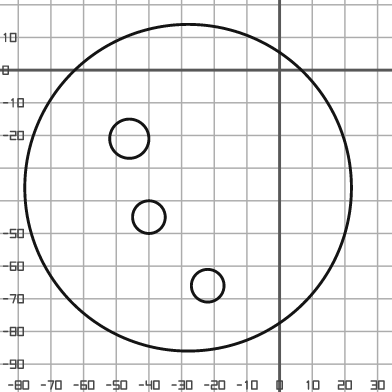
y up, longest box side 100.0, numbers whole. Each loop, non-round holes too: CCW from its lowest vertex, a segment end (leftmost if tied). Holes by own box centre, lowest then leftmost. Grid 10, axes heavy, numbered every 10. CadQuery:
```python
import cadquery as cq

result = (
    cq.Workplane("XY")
    .moveTo(-28.0, -36.0)
    .circle(50.0)
    .moveTo(-22.0, -66.0)
    .circle(5.0)
    .moveTo(-40.0, -45.0)
    .circle(5.0)
    .moveTo(-46.0, -21.0)
    .circle(6.0)
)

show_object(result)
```